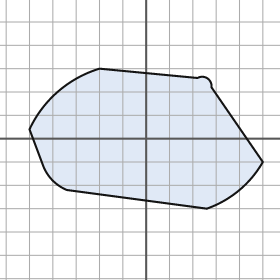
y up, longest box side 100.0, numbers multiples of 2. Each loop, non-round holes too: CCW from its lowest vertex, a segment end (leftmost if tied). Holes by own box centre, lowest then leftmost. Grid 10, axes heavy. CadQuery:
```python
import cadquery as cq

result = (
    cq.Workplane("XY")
    .moveTo(26.0, -30.0)
    .threePointArc((40.0, -22.0), (50.0, -10.0))
    .lineTo(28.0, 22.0)
    .threePointArc((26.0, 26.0), (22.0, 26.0))
    .lineTo(-20.0, 30.0)
    .threePointArc((-38.0, 20.0), (-50.0, 4.0))
    .lineTo(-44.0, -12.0)
    .threePointArc((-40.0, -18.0), (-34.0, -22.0))
    .close()
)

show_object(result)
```